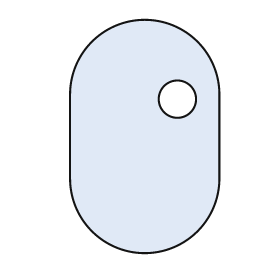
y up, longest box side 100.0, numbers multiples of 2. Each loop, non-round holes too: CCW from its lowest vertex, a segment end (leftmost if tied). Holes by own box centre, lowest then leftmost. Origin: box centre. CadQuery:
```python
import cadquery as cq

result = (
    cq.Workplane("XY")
    .moveTo(-32.0, -18.0)
    .threePointArc((0.0, -50.0), (32.0, -18.0))
    .lineTo(32.0, 18.0)
    .threePointArc((0.0, 50.0), (-32.0, 18.0))
    .close()
    .moveTo(14.0, 16.0)
    .circle(8.0)
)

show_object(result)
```